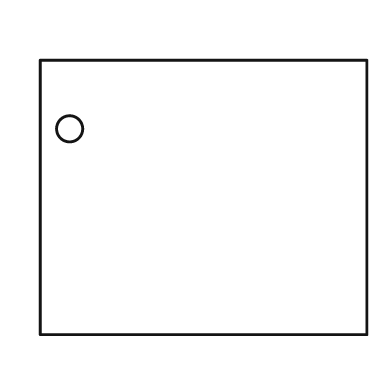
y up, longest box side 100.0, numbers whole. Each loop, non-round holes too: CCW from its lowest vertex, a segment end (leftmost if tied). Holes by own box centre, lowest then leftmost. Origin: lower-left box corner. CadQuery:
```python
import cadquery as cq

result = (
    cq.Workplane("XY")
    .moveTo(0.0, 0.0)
    .lineTo(100.0, 0.0)
    .lineTo(100.0, 84.0)
    .lineTo(0.0, 84.0)
    .close()
    .moveTo(9.0, 63.0)
    .circle(4.0)
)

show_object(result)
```